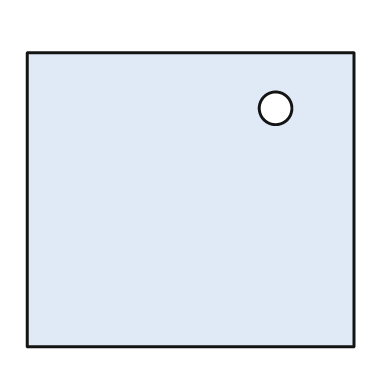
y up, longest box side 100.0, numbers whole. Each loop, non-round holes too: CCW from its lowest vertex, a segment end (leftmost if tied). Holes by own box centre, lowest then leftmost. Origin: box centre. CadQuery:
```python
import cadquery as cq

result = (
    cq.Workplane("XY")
    .moveTo(-50.0, -45.0)
    .lineTo(50.0, -45.0)
    .lineTo(50.0, 45.0)
    .lineTo(-50.0, 45.0)
    .close()
    .moveTo(26.0, 28.0)
    .circle(5.0)
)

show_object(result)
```